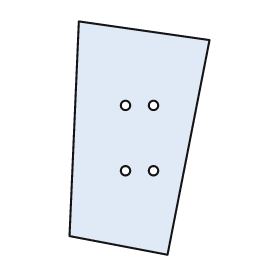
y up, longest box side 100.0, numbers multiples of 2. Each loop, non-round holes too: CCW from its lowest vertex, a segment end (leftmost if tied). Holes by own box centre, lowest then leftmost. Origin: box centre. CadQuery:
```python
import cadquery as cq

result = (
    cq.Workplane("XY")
    .moveTo(12.0, -50.0)
    .lineTo(30.0, 42.0)
    .lineTo(-26.0, 50.0)
    .lineTo(-30.0, -42.0)
    .close()
    .moveTo(-6.0, -14.0)
    .circle(2.0)
    .moveTo(6.0, -14.0)
    .circle(2.0)
    .moveTo(-6.0, 14.0)
    .circle(2.0)
    .moveTo(6.0, 14.0)
    .circle(2.0)
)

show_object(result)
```